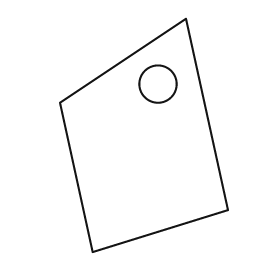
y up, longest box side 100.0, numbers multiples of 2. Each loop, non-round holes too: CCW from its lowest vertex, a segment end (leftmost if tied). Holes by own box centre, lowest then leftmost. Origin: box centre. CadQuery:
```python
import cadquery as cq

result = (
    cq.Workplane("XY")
    .moveTo(-22.0, -50.0)
    .lineTo(36.0, -32.0)
    .lineTo(18.0, 50.0)
    .lineTo(-36.0, 14.0)
    .close()
    .moveTo(6.0, 22.0)
    .circle(8.0)
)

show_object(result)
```